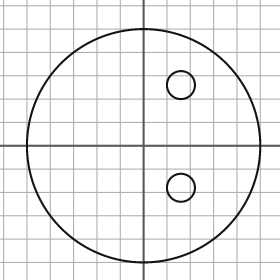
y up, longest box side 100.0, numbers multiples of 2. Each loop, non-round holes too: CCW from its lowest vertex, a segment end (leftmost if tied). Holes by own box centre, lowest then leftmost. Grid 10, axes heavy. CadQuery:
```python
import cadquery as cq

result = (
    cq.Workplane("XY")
    .moveTo(0.0, 0.0)
    .circle(50.0)
    .moveTo(16.0, -18.0)
    .circle(6.0)
    .moveTo(16.0, 26.0)
    .circle(6.0)
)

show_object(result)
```